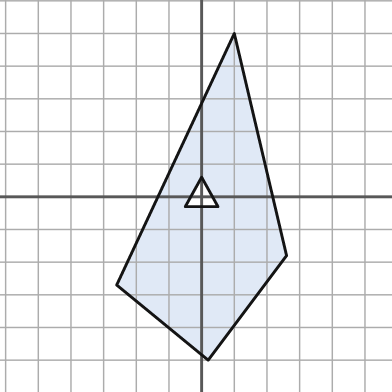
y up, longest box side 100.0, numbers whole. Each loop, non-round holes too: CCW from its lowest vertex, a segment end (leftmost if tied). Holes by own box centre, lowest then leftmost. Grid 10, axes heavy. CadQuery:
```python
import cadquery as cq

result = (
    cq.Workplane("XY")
    .moveTo(2.0, -50.0)
    .lineTo(26.0, -18.0)
    .lineTo(10.0, 50.0)
    .lineTo(-26.0, -27.0)
    .close()
    .moveTo(-5.0, -3.0)
    .lineTo(5.0, -3.0)
    .lineTo(0.0, 6.0)
    .close()
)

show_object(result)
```